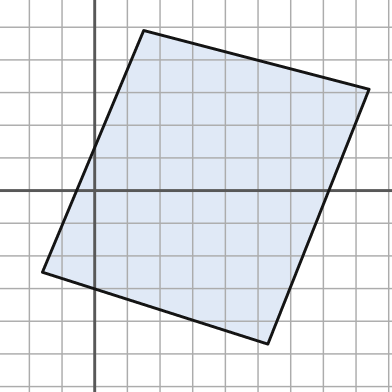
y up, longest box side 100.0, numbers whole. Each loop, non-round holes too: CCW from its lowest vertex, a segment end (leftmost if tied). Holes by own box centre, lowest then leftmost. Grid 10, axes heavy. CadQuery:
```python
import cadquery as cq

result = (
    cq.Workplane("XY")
    .moveTo(53.0, -47.0)
    .lineTo(84.0, 31.0)
    .lineTo(15.0, 49.0)
    .lineTo(-16.0, -25.0)
    .close()
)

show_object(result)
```